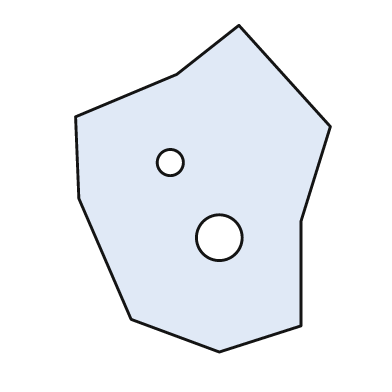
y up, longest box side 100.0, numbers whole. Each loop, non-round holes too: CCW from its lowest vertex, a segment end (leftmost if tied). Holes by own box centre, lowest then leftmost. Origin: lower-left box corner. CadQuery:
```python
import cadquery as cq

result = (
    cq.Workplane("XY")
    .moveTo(44.0, 0.0)
    .lineTo(69.0, 8.0)
    .lineTo(69.0, 40.0)
    .lineTo(78.0, 69.0)
    .lineTo(50.0, 100.0)
    .lineTo(31.0, 85.0)
    .lineTo(0.0, 72.0)
    .lineTo(1.0, 47.0)
    .lineTo(17.0, 10.0)
    .close()
    .moveTo(44.0, 35.0)
    .circle(7.0)
    .moveTo(29.0, 58.0)
    .circle(4.0)
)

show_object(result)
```